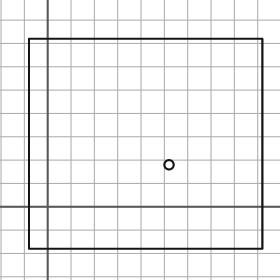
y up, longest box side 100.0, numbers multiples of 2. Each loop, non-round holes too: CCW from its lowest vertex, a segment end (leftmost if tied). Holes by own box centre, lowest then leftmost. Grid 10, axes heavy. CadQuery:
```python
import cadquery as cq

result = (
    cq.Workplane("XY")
    .moveTo(-8.0, -18.0)
    .lineTo(92.0, -18.0)
    .lineTo(92.0, 72.0)
    .lineTo(-8.0, 72.0)
    .close()
    .moveTo(52.0, 18.0)
    .circle(2.0)
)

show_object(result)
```